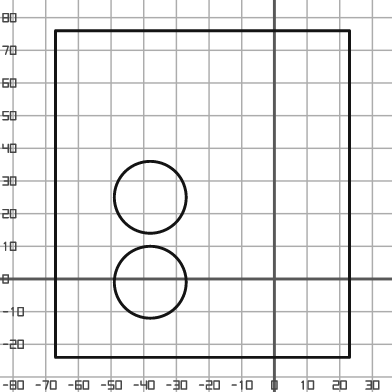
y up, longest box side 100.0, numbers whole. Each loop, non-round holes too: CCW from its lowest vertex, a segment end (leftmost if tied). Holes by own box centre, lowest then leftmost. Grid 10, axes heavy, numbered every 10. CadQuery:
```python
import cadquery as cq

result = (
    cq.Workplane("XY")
    .moveTo(-67.0, -24.0)
    .lineTo(23.0, -24.0)
    .lineTo(23.0, 76.0)
    .lineTo(-67.0, 76.0)
    .close()
    .moveTo(-38.0, -1.0)
    .circle(11.0)
    .moveTo(-38.0, 25.0)
    .circle(11.0)
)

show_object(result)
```